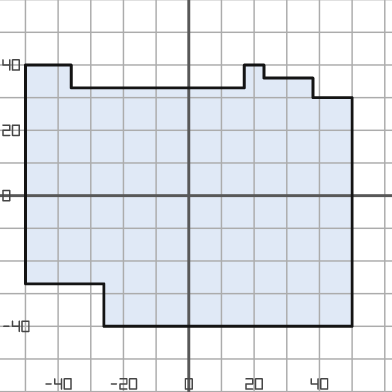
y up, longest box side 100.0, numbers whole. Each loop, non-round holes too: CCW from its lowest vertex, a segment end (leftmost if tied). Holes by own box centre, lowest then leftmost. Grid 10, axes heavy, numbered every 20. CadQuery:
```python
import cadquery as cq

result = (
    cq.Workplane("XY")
    .moveTo(-26.0, -40.0)
    .lineTo(50.0, -40.0)
    .lineTo(50.0, 30.0)
    .lineTo(38.0, 30.0)
    .lineTo(38.0, 36.0)
    .lineTo(23.0, 36.0)
    .lineTo(23.0, 40.0)
    .lineTo(17.0, 40.0)
    .lineTo(17.0, 33.0)
    .lineTo(-36.0, 33.0)
    .lineTo(-36.0, 40.0)
    .lineTo(-50.0, 40.0)
    .lineTo(-50.0, -27.0)
    .lineTo(-26.0, -27.0)
    .close()
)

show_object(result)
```